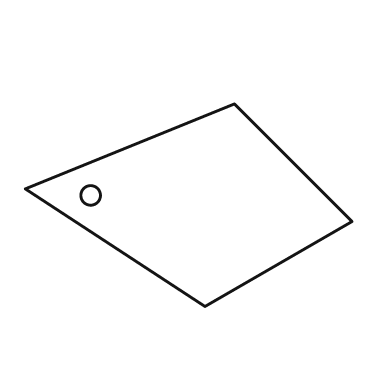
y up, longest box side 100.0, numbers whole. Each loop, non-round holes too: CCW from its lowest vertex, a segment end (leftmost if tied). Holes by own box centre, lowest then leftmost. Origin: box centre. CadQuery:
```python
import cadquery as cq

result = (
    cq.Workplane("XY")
    .moveTo(5.0, -31.0)
    .lineTo(50.0, -5.0)
    .lineTo(14.0, 31.0)
    .lineTo(-50.0, 5.0)
    .close()
    .moveTo(-30.0, 3.0)
    .circle(3.0)
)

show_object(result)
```